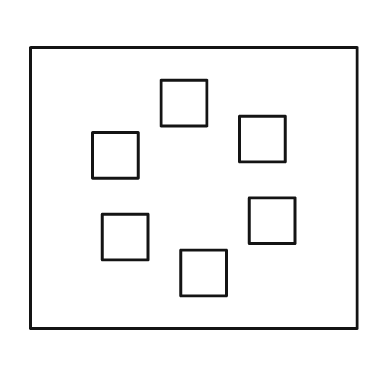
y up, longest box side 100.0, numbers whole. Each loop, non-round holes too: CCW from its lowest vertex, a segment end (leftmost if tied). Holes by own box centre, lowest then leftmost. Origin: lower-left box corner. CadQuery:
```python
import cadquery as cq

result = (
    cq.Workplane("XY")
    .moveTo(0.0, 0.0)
    .lineTo(100.0, 0.0)
    .lineTo(100.0, 86.0)
    .lineTo(0.0, 86.0)
    .close()
    .moveTo(46.0, 10.0)
    .lineTo(60.0, 10.0)
    .lineTo(60.0, 24.0)
    .lineTo(46.0, 24.0)
    .close()
    .moveTo(22.0, 21.0)
    .lineTo(36.0, 21.0)
    .lineTo(36.0, 35.0)
    .lineTo(22.0, 35.0)
    .close()
    .moveTo(67.0, 26.0)
    .lineTo(81.0, 26.0)
    .lineTo(81.0, 40.0)
    .lineTo(67.0, 40.0)
    .close()
    .moveTo(19.0, 46.0)
    .lineTo(33.0, 46.0)
    .lineTo(33.0, 60.0)
    .lineTo(19.0, 60.0)
    .close()
    .moveTo(64.0, 51.0)
    .lineTo(78.0, 51.0)
    .lineTo(78.0, 65.0)
    .lineTo(64.0, 65.0)
    .close()
    .moveTo(40.0, 62.0)
    .lineTo(54.0, 62.0)
    .lineTo(54.0, 76.0)
    .lineTo(40.0, 76.0)
    .close()
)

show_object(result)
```